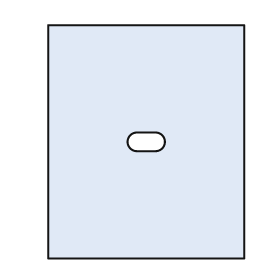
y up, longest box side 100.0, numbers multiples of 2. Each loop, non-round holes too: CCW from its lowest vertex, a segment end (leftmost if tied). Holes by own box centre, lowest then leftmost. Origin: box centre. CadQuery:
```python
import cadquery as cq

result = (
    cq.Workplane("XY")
    .moveTo(-42.0, -50.0)
    .lineTo(42.0, -50.0)
    .lineTo(42.0, 50.0)
    .lineTo(-42.0, 50.0)
    .close()
    .moveTo(-4.0, -4.0)
    .lineTo(4.0, -4.0)
    .threePointArc((8.0, 0.0), (4.0, 4.0))
    .lineTo(-4.0, 4.0)
    .threePointArc((-8.0, 0.0), (-4.0, -4.0))
    .close()
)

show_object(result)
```